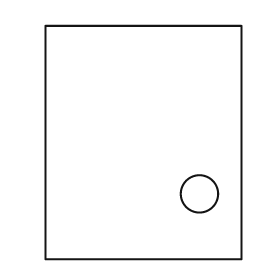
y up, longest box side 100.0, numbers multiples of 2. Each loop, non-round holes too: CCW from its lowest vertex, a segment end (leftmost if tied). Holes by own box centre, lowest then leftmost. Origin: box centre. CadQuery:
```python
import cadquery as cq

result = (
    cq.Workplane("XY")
    .moveTo(-42.0, -50.0)
    .lineTo(42.0, -50.0)
    .lineTo(42.0, 50.0)
    .lineTo(-42.0, 50.0)
    .close()
    .moveTo(24.0, -22.0)
    .circle(8.0)
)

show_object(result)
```